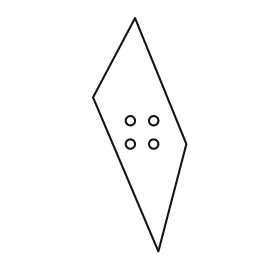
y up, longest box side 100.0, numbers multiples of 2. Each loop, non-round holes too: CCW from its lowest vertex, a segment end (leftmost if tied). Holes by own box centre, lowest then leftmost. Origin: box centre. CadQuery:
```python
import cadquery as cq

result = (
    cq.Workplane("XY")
    .moveTo(8.0, -50.0)
    .lineTo(20.0, -4.0)
    .lineTo(-2.0, 50.0)
    .lineTo(-20.0, 16.0)
    .close()
    .moveTo(-4.0, -4.0)
    .circle(2.0)
    .moveTo(6.0, -4.0)
    .circle(2.0)
    .moveTo(-4.0, 6.0)
    .circle(2.0)
    .moveTo(6.0, 6.0)
    .circle(2.0)
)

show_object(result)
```